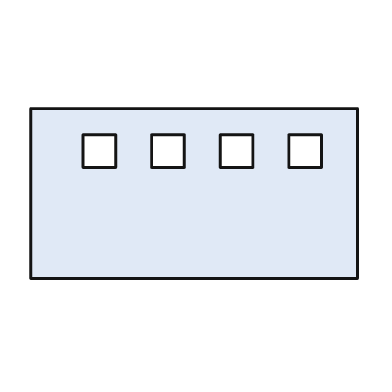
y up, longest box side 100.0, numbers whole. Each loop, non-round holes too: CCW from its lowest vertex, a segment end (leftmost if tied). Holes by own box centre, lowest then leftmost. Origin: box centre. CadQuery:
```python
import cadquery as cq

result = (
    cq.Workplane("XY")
    .moveTo(-50.0, -26.0)
    .lineTo(50.0, -26.0)
    .lineTo(50.0, 26.0)
    .lineTo(-50.0, 26.0)
    .close()
    .moveTo(-34.0, 8.0)
    .lineTo(-24.0, 8.0)
    .lineTo(-24.0, 18.0)
    .lineTo(-34.0, 18.0)
    .close()
    .moveTo(-13.0, 8.0)
    .lineTo(-3.0, 8.0)
    .lineTo(-3.0, 18.0)
    .lineTo(-13.0, 18.0)
    .close()
    .moveTo(8.0, 8.0)
    .lineTo(18.0, 8.0)
    .lineTo(18.0, 18.0)
    .lineTo(8.0, 18.0)
    .close()
    .moveTo(29.0, 8.0)
    .lineTo(39.0, 8.0)
    .lineTo(39.0, 18.0)
    .lineTo(29.0, 18.0)
    .close()
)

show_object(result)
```